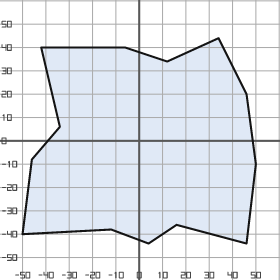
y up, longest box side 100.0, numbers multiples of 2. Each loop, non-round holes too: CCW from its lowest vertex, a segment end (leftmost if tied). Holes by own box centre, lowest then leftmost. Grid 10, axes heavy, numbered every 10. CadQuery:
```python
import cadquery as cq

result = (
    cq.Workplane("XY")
    .moveTo(4.0, -44.0)
    .lineTo(16.0, -36.0)
    .lineTo(46.0, -44.0)
    .lineTo(50.0, -10.0)
    .lineTo(46.0, 20.0)
    .lineTo(34.0, 44.0)
    .lineTo(12.0, 34.0)
    .lineTo(-6.0, 40.0)
    .lineTo(-42.0, 40.0)
    .lineTo(-34.0, 6.0)
    .lineTo(-46.0, -8.0)
    .lineTo(-50.0, -40.0)
    .lineTo(-12.0, -38.0)
    .close()
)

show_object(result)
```